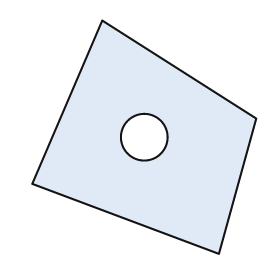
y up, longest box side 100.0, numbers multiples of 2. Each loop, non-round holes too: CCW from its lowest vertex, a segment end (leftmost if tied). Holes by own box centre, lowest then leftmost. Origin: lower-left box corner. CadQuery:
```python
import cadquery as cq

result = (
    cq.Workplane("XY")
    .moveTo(80.0, 0.0)
    .lineTo(96.0, 58.0)
    .lineTo(30.0, 100.0)
    .lineTo(0.0, 30.0)
    .close()
    .moveTo(48.0, 50.0)
    .circle(10.0)
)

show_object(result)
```